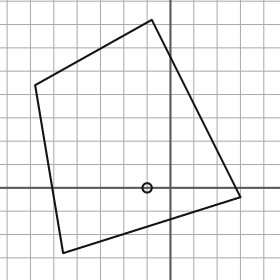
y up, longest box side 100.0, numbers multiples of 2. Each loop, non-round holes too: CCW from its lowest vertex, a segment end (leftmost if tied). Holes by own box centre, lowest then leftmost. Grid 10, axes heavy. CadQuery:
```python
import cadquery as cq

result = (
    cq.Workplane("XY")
    .moveTo(-46.0, -28.0)
    .lineTo(30.0, -4.0)
    .lineTo(-8.0, 72.0)
    .lineTo(-58.0, 44.0)
    .close()
    .moveTo(-10.0, 0.0)
    .circle(2.0)
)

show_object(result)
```